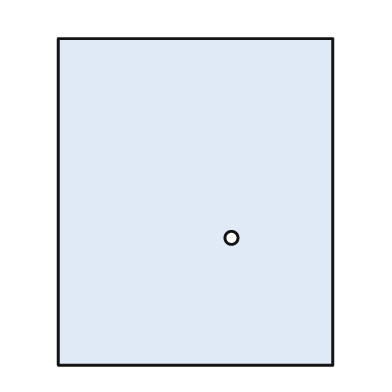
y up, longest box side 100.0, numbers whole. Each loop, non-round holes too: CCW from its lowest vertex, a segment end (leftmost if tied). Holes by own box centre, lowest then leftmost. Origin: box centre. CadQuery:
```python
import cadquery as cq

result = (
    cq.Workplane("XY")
    .moveTo(-42.0, -50.0)
    .lineTo(42.0, -50.0)
    .lineTo(42.0, 50.0)
    .lineTo(-42.0, 50.0)
    .close()
    .moveTo(11.0, -11.0)
    .circle(2.0)
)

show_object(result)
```